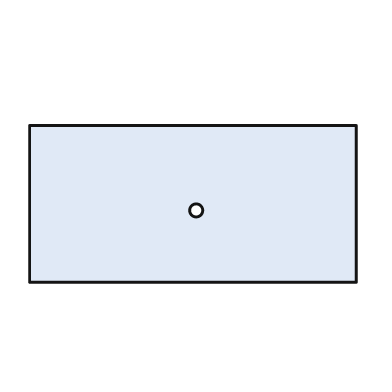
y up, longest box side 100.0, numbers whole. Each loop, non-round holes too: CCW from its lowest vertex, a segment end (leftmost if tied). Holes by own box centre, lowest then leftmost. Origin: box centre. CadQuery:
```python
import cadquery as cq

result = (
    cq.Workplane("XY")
    .moveTo(-50.0, -24.0)
    .lineTo(50.0, -24.0)
    .lineTo(50.0, 24.0)
    .lineTo(-50.0, 24.0)
    .close()
    .moveTo(1.0, -2.0)
    .circle(2.0)
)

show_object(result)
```